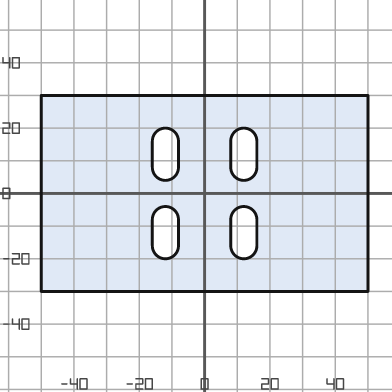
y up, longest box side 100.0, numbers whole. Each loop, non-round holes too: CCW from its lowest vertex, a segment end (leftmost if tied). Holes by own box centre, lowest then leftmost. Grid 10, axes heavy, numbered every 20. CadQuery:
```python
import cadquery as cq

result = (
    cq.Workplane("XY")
    .moveTo(-50.0, -30.0)
    .lineTo(50.0, -30.0)
    .lineTo(50.0, 30.0)
    .lineTo(-50.0, 30.0)
    .close()
    .moveTo(-16.0, -16.0)
    .threePointArc((-12.0, -20.0), (-8.0, -16.0))
    .lineTo(-8.0, -8.0)
    .threePointArc((-12.0, -4.0), (-16.0, -8.0))
    .close()
    .moveTo(8.0, -16.0)
    .threePointArc((12.0, -20.0), (16.0, -16.0))
    .lineTo(16.0, -8.0)
    .threePointArc((12.0, -4.0), (8.0, -8.0))
    .close()
    .moveTo(-16.0, 8.0)
    .threePointArc((-12.0, 4.0), (-8.0, 8.0))
    .lineTo(-8.0, 16.0)
    .threePointArc((-12.0, 20.0), (-16.0, 16.0))
    .close()
    .moveTo(8.0, 8.0)
    .threePointArc((12.0, 4.0), (16.0, 8.0))
    .lineTo(16.0, 16.0)
    .threePointArc((12.0, 20.0), (8.0, 16.0))
    .close()
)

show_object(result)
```